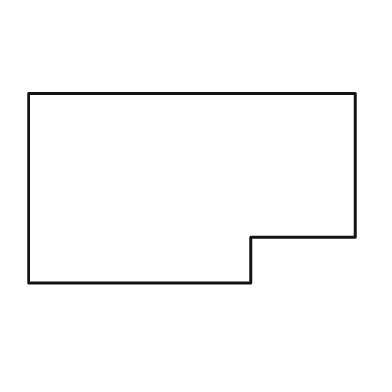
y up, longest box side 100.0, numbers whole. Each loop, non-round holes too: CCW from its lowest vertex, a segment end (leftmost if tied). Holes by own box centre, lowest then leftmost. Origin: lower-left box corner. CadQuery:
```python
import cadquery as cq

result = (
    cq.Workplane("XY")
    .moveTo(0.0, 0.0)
    .lineTo(68.0, 0.0)
    .lineTo(68.0, 14.0)
    .lineTo(100.0, 14.0)
    .lineTo(100.0, 58.0)
    .lineTo(0.0, 58.0)
    .close()
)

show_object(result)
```